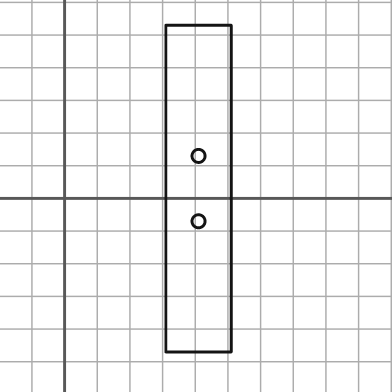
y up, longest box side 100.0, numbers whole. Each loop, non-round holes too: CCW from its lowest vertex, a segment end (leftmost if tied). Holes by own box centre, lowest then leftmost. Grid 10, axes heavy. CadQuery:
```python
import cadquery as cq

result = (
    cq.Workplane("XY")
    .moveTo(31.0, -47.0)
    .lineTo(51.0, -47.0)
    .lineTo(51.0, 53.0)
    .lineTo(31.0, 53.0)
    .close()
    .moveTo(41.0, -7.0)
    .circle(2.0)
    .moveTo(41.0, 13.0)
    .circle(2.0)
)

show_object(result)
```